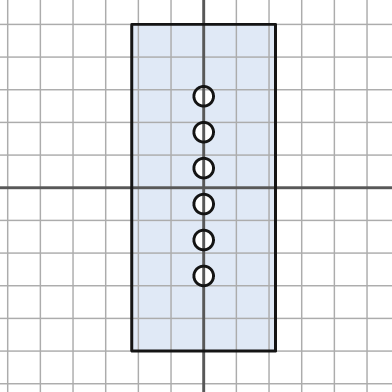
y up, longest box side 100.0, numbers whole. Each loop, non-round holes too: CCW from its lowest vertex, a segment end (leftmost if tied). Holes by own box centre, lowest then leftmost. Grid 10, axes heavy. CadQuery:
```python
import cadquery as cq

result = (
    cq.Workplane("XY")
    .moveTo(-22.0, -50.0)
    .lineTo(22.0, -50.0)
    .lineTo(22.0, 50.0)
    .lineTo(-22.0, 50.0)
    .close()
    .moveTo(0.0, -27.0)
    .circle(3.0)
    .moveTo(0.0, -16.0)
    .circle(3.0)
    .moveTo(0.0, -5.0)
    .circle(3.0)
    .moveTo(0.0, 6.0)
    .circle(3.0)
    .moveTo(0.0, 17.0)
    .circle(3.0)
    .moveTo(0.0, 28.0)
    .circle(3.0)
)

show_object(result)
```